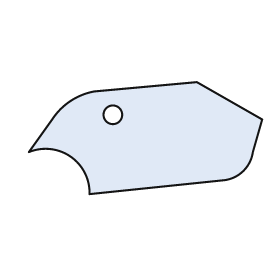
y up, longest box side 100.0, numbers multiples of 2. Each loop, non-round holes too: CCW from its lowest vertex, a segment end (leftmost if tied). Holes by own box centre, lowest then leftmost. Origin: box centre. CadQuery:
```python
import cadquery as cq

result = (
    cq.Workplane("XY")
    .moveTo(-24.0, -24.0)
    .lineTo(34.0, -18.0)
    .threePointArc((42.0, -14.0), (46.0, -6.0))
    .lineTo(50.0, 8.0)
    .lineTo(22.0, 24.0)
    .lineTo(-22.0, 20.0)
    .threePointArc((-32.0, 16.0), (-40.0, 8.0))
    .lineTo(-50.0, -6.0)
    .threePointArc((-32.0, -8.0), (-24.0, -24.0))
    .close()
    .moveTo(-14.0, 10.0)
    .circle(4.0)
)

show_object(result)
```